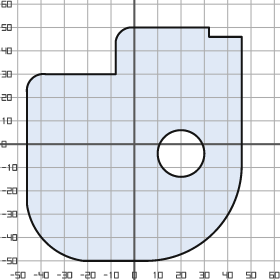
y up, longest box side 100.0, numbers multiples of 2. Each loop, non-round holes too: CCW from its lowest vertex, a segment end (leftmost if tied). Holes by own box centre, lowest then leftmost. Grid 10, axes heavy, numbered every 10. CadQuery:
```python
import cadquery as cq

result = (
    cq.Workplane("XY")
    .moveTo(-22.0, -50.0)
    .lineTo(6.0, -50.0)
    .threePointArc((34.0, -38.0), (46.0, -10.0))
    .lineTo(46.0, 46.0)
    .lineTo(32.0, 46.0)
    .lineTo(32.0, 50.0)
    .lineTo(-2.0, 50.0)
    .threePointArc((-6.0, 48.0), (-8.0, 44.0))
    .lineTo(-8.0, 30.0)
    .lineTo(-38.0, 30.0)
    .threePointArc((-44.0, 28.0), (-46.0, 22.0))
    .lineTo(-46.0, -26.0)
    .threePointArc((-38.0, -42.0), (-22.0, -50.0))
    .close()
    .moveTo(20.0, -4.0)
    .circle(10.0)
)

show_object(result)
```